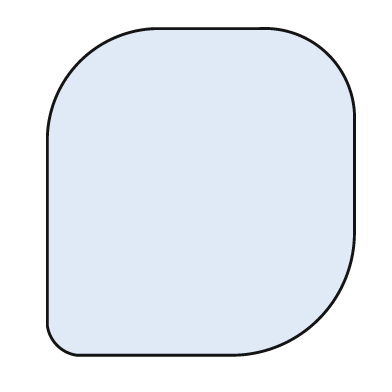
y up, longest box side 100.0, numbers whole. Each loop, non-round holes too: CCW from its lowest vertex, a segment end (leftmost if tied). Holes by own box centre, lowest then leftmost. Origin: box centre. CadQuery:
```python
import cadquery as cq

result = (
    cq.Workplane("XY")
    .moveTo(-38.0, -50.0)
    .lineTo(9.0, -50.0)
    .threePointArc((36.0, -39.0), (47.0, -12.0))
    .lineTo(47.0, 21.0)
    .threePointArc((39.0, 42.0), (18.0, 50.0))
    .lineTo(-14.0, 50.0)
    .threePointArc((-37.0, 40.0), (-47.0, 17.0))
    .lineTo(-47.0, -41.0)
    .threePointArc((-44.0, -47.0), (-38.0, -50.0))
    .close()
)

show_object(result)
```